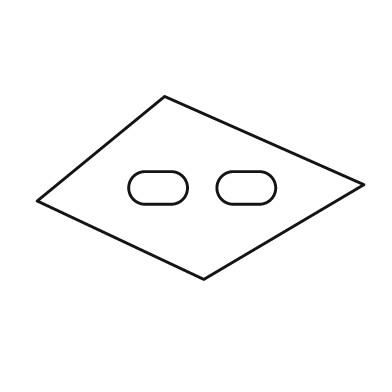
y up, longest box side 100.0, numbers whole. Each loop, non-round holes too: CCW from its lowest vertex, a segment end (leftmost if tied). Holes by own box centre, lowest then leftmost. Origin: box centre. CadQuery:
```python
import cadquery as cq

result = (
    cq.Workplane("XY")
    .moveTo(1.0, -28.0)
    .lineTo(50.0, 1.0)
    .lineTo(-11.0, 28.0)
    .lineTo(-50.0, -4.0)
    .close()
    .moveTo(-17.0, -5.0)
    .lineTo(-9.0, -5.0)
    .threePointArc((-4.0, 0.0), (-9.0, 5.0))
    .lineTo(-17.0, 5.0)
    .threePointArc((-22.0, 0.0), (-17.0, -5.0))
    .close()
    .moveTo(10.0, -5.0)
    .lineTo(18.0, -5.0)
    .threePointArc((23.0, 0.0), (18.0, 5.0))
    .lineTo(10.0, 5.0)
    .threePointArc((5.0, 0.0), (10.0, -5.0))
    .close()
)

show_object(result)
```